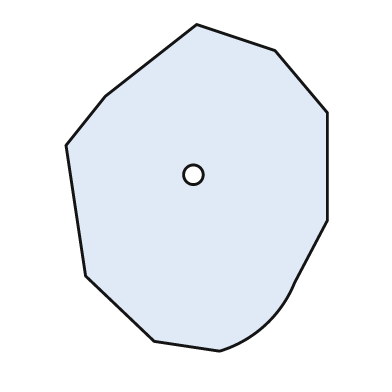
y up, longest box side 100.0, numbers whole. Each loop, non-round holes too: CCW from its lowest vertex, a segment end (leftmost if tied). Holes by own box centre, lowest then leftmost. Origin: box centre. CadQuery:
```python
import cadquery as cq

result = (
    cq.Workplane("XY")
    .moveTo(7.0, -50.0)
    .threePointArc((21.0, -42.0), (30.0, -29.0))
    .lineTo(40.0, -10.0)
    .lineTo(40.0, 23.0)
    .lineTo(24.0, 42.0)
    .lineTo(0.0, 50.0)
    .lineTo(-28.0, 28.0)
    .lineTo(-40.0, 13.0)
    .lineTo(-34.0, -27.0)
    .lineTo(-13.0, -47.0)
    .close()
    .moveTo(-1.0, 4.0)
    .circle(3.0)
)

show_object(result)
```